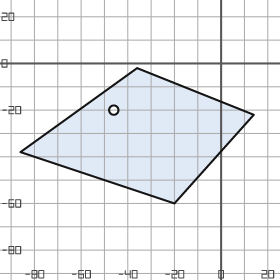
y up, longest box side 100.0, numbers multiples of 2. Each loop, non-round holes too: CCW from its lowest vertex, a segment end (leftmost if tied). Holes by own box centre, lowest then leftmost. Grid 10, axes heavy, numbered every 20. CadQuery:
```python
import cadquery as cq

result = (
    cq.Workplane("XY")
    .moveTo(-20.0, -60.0)
    .lineTo(14.0, -22.0)
    .lineTo(-36.0, -2.0)
    .lineTo(-86.0, -38.0)
    .close()
    .moveTo(-46.0, -20.0)
    .circle(2.0)
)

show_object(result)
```